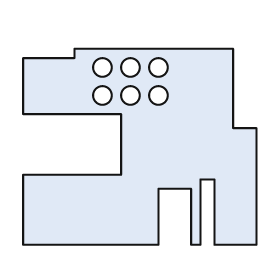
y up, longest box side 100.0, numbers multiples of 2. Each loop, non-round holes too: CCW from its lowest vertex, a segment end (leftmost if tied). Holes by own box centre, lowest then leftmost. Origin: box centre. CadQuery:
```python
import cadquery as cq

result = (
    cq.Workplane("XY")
    .moveTo(-50.0, -42.0)
    .lineTo(8.0, -42.0)
    .lineTo(8.0, -18.0)
    .lineTo(22.0, -18.0)
    .lineTo(22.0, -42.0)
    .lineTo(26.0, -42.0)
    .lineTo(26.0, -14.0)
    .lineTo(32.0, -14.0)
    .lineTo(32.0, -42.0)
    .lineTo(50.0, -42.0)
    .lineTo(50.0, 8.0)
    .lineTo(40.0, 8.0)
    .lineTo(40.0, 42.0)
    .lineTo(-28.0, 42.0)
    .lineTo(-28.0, 38.0)
    .lineTo(-50.0, 38.0)
    .lineTo(-50.0, 14.0)
    .lineTo(-8.0, 14.0)
    .lineTo(-8.0, -12.0)
    .lineTo(-50.0, -12.0)
    .close()
    .moveTo(-16.0, 22.0)
    .circle(4.0)
    .moveTo(-4.0, 22.0)
    .circle(4.0)
    .moveTo(8.0, 22.0)
    .circle(4.0)
    .moveTo(-16.0, 34.0)
    .circle(4.0)
    .moveTo(-4.0, 34.0)
    .circle(4.0)
    .moveTo(8.0, 34.0)
    .circle(4.0)
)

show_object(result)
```